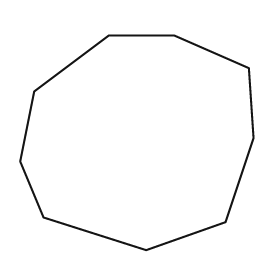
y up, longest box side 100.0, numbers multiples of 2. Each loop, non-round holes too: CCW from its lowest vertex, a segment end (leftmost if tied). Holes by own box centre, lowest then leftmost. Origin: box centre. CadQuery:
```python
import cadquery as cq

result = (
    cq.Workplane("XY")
    .moveTo(4.0, -46.0)
    .lineTo(38.0, -34.0)
    .lineTo(50.0, 2.0)
    .lineTo(48.0, 32.0)
    .lineTo(16.0, 46.0)
    .lineTo(-12.0, 46.0)
    .lineTo(-44.0, 22.0)
    .lineTo(-50.0, -8.0)
    .lineTo(-40.0, -32.0)
    .close()
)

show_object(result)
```